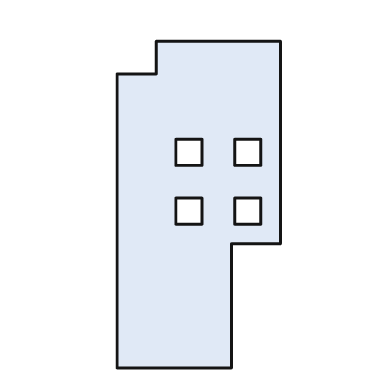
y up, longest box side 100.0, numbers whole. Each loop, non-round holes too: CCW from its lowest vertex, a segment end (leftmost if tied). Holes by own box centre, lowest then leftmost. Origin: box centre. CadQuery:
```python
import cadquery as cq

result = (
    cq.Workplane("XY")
    .moveTo(-25.0, -50.0)
    .lineTo(10.0, -50.0)
    .lineTo(10.0, -12.0)
    .lineTo(25.0, -12.0)
    .lineTo(25.0, 50.0)
    .lineTo(-13.0, 50.0)
    .lineTo(-13.0, 40.0)
    .lineTo(-25.0, 40.0)
    .close()
    .moveTo(-7.0, -6.0)
    .lineTo(1.0, -6.0)
    .lineTo(1.0, 2.0)
    .lineTo(-7.0, 2.0)
    .close()
    .moveTo(11.0, -6.0)
    .lineTo(19.0, -6.0)
    .lineTo(19.0, 2.0)
    .lineTo(11.0, 2.0)
    .close()
    .moveTo(-7.0, 12.0)
    .lineTo(1.0, 12.0)
    .lineTo(1.0, 20.0)
    .lineTo(-7.0, 20.0)
    .close()
    .moveTo(11.0, 12.0)
    .lineTo(19.0, 12.0)
    .lineTo(19.0, 20.0)
    .lineTo(11.0, 20.0)
    .close()
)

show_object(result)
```